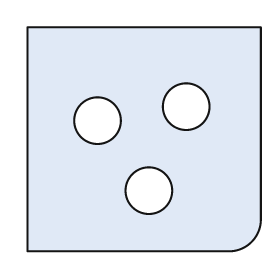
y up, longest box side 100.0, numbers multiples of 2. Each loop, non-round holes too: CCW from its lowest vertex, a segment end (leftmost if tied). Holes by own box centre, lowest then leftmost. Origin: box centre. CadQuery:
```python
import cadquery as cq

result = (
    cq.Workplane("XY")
    .moveTo(-50.0, -48.0)
    .lineTo(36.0, -48.0)
    .threePointArc((46.0, -44.0), (50.0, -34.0))
    .lineTo(50.0, 48.0)
    .lineTo(-50.0, 48.0)
    .close()
    .moveTo(2.0, -22.0)
    .circle(10.0)
    .moveTo(-20.0, 8.0)
    .circle(10.0)
    .moveTo(18.0, 14.0)
    .circle(10.0)
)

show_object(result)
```